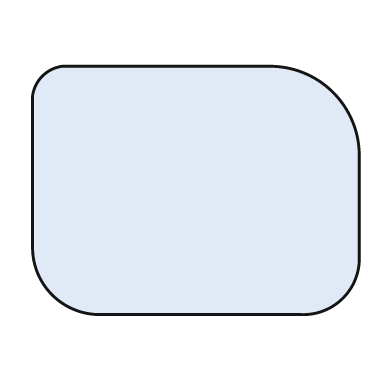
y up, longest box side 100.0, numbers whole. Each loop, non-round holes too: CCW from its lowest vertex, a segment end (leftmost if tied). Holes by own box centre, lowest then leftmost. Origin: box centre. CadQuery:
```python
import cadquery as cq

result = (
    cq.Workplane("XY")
    .moveTo(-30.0, -38.0)
    .lineTo(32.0, -38.0)
    .threePointArc((45.0, -33.0), (50.0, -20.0))
    .lineTo(50.0, 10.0)
    .threePointArc((42.0, 30.0), (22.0, 38.0))
    .lineTo(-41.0, 38.0)
    .threePointArc((-47.0, 35.0), (-50.0, 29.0))
    .lineTo(-50.0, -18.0)
    .threePointArc((-44.0, -32.0), (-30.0, -38.0))
    .close()
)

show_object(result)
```